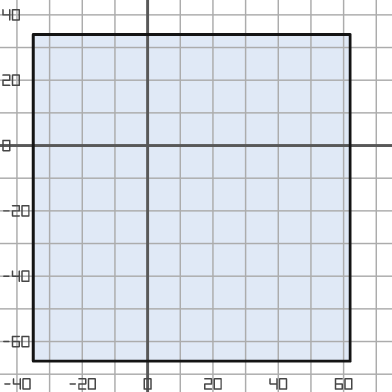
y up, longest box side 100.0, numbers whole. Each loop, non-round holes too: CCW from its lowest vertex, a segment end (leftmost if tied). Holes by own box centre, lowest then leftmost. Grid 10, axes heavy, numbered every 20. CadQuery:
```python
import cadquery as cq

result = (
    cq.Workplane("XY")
    .moveTo(-35.0, -66.0)
    .lineTo(62.0, -66.0)
    .lineTo(62.0, 34.0)
    .lineTo(-35.0, 34.0)
    .close()
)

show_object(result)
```